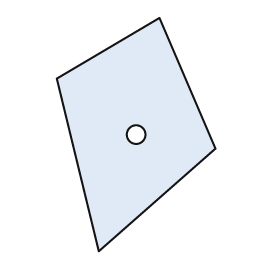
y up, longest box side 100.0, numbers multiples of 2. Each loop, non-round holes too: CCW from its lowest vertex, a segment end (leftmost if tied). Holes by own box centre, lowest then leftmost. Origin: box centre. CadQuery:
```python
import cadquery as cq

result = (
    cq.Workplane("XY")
    .moveTo(-16.0, -50.0)
    .lineTo(34.0, -6.0)
    .lineTo(10.0, 50.0)
    .lineTo(-34.0, 24.0)
    .close()
    .moveTo(0.0, 0.0)
    .circle(4.0)
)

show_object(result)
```